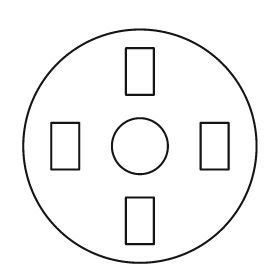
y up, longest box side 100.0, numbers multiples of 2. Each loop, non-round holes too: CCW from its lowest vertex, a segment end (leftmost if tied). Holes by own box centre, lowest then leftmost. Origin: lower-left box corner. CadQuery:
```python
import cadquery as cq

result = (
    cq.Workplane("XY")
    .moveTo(50.0, 50.0)
    .circle(50.0)
    .moveTo(44.0, 8.0)
    .lineTo(56.0, 8.0)
    .lineTo(56.0, 28.0)
    .lineTo(44.0, 28.0)
    .close()
    .moveTo(12.0, 40.0)
    .lineTo(24.0, 40.0)
    .lineTo(24.0, 60.0)
    .lineTo(12.0, 60.0)
    .close()
    .moveTo(50.0, 50.0)
    .circle(12.0)
    .moveTo(76.0, 40.0)
    .lineTo(88.0, 40.0)
    .lineTo(88.0, 60.0)
    .lineTo(76.0, 60.0)
    .close()
    .moveTo(44.0, 72.0)
    .lineTo(56.0, 72.0)
    .lineTo(56.0, 92.0)
    .lineTo(44.0, 92.0)
    .close()
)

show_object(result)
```